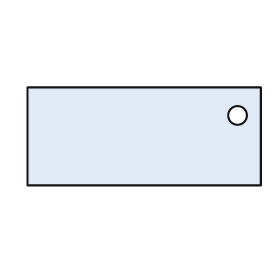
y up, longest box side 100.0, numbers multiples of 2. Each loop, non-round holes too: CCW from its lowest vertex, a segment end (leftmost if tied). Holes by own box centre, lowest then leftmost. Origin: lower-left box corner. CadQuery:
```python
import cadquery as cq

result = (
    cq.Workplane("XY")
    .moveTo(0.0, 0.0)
    .lineTo(100.0, 0.0)
    .lineTo(100.0, 42.0)
    .lineTo(0.0, 42.0)
    .close()
    .moveTo(90.0, 30.0)
    .circle(4.0)
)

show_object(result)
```